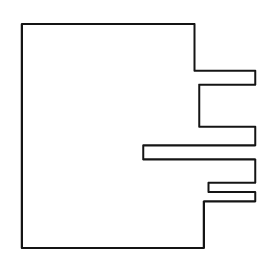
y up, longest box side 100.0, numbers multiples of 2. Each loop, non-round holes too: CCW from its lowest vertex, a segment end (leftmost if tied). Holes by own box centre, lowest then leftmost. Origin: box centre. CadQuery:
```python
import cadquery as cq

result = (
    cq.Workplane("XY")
    .moveTo(-50.0, -48.0)
    .lineTo(28.0, -48.0)
    .lineTo(28.0, -28.0)
    .lineTo(50.0, -28.0)
    .lineTo(50.0, -24.0)
    .lineTo(30.0, -24.0)
    .lineTo(30.0, -20.0)
    .lineTo(50.0, -20.0)
    .lineTo(50.0, -10.0)
    .lineTo(2.0, -10.0)
    .lineTo(2.0, -4.0)
    .lineTo(50.0, -4.0)
    .lineTo(50.0, 4.0)
    .lineTo(26.0, 4.0)
    .lineTo(26.0, 22.0)
    .lineTo(50.0, 22.0)
    .lineTo(50.0, 28.0)
    .lineTo(24.0, 28.0)
    .lineTo(24.0, 48.0)
    .lineTo(-50.0, 48.0)
    .close()
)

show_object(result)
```